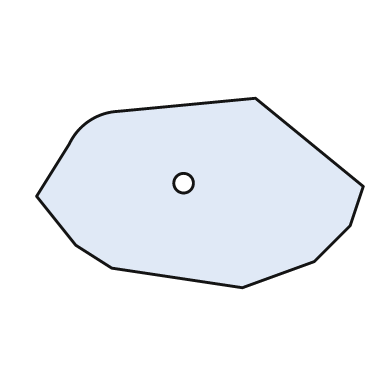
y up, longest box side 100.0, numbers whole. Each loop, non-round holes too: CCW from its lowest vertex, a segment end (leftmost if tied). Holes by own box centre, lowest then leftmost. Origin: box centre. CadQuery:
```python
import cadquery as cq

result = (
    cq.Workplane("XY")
    .moveTo(13.0, -29.0)
    .lineTo(35.0, -21.0)
    .lineTo(46.0, -10.0)
    .lineTo(50.0, 2.0)
    .lineTo(17.0, 29.0)
    .lineTo(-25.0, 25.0)
    .threePointArc((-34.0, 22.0), (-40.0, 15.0))
    .lineTo(-50.0, -1.0)
    .lineTo(-38.0, -16.0)
    .lineTo(-27.0, -23.0)
    .close()
    .moveTo(-5.0, 3.0)
    .circle(3.0)
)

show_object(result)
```